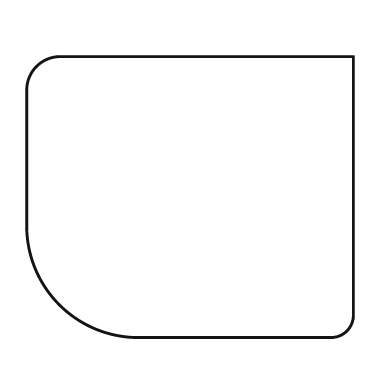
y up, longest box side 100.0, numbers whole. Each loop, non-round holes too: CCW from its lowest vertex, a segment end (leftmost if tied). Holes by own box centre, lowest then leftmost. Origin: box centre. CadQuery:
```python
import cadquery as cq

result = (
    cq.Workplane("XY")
    .moveTo(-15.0, -43.0)
    .lineTo(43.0, -43.0)
    .threePointArc((48.0, -41.0), (50.0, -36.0))
    .lineTo(50.0, 43.0)
    .lineTo(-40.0, 43.0)
    .threePointArc((-47.0, 40.0), (-50.0, 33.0))
    .lineTo(-50.0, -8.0)
    .threePointArc((-40.0, -33.0), (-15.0, -43.0))
    .close()
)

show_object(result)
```